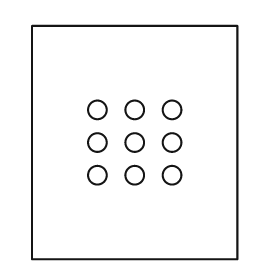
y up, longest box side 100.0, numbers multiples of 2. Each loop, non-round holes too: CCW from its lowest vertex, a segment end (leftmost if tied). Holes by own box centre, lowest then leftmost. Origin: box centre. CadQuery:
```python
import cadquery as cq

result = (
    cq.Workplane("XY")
    .moveTo(-44.0, -50.0)
    .lineTo(44.0, -50.0)
    .lineTo(44.0, 50.0)
    .lineTo(-44.0, 50.0)
    .close()
    .moveTo(-16.0, -14.0)
    .circle(4.0)
    .moveTo(0.0, -14.0)
    .circle(4.0)
    .moveTo(16.0, -14.0)
    .circle(4.0)
    .moveTo(-16.0, 0.0)
    .circle(4.0)
    .moveTo(0.0, 0.0)
    .circle(4.0)
    .moveTo(16.0, 0.0)
    .circle(4.0)
    .moveTo(-16.0, 14.0)
    .circle(4.0)
    .moveTo(0.0, 14.0)
    .circle(4.0)
    .moveTo(16.0, 14.0)
    .circle(4.0)
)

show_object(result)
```